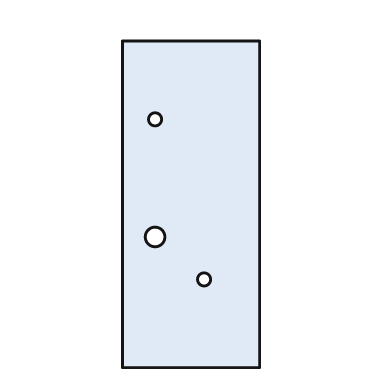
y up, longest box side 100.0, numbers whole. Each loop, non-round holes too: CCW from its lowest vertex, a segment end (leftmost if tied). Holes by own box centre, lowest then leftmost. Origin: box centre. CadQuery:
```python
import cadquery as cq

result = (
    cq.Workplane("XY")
    .moveTo(-21.0, -50.0)
    .lineTo(21.0, -50.0)
    .lineTo(21.0, 50.0)
    .lineTo(-21.0, 50.0)
    .close()
    .moveTo(4.0, -23.0)
    .circle(2.0)
    .moveTo(-11.0, -10.0)
    .circle(3.0)
    .moveTo(-11.0, 26.0)
    .circle(2.0)
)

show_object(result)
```